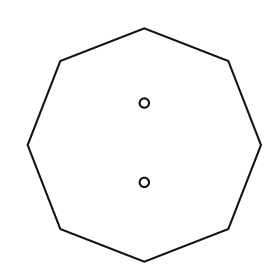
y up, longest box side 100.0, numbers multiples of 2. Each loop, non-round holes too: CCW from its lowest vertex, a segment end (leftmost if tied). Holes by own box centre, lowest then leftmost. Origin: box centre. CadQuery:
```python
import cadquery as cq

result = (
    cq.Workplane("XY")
    .moveTo(0.0, -50.0)
    .lineTo(36.0, -36.0)
    .lineTo(50.0, 0.0)
    .lineTo(36.0, 36.0)
    .lineTo(0.0, 50.0)
    .lineTo(-36.0, 36.0)
    .lineTo(-50.0, 0.0)
    .lineTo(-36.0, -36.0)
    .close()
    .moveTo(0.0, -16.0)
    .circle(2.0)
    .moveTo(0.0, 18.0)
    .circle(2.0)
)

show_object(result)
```